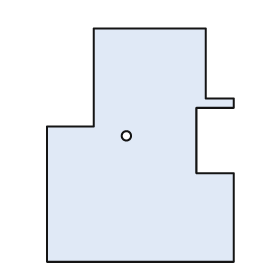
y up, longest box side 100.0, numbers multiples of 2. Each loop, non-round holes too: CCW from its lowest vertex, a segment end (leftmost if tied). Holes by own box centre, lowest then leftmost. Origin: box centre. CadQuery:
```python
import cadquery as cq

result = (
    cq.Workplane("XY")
    .moveTo(-40.0, -50.0)
    .lineTo(40.0, -50.0)
    .lineTo(40.0, -12.0)
    .lineTo(24.0, -12.0)
    .lineTo(24.0, 16.0)
    .lineTo(40.0, 16.0)
    .lineTo(40.0, 20.0)
    .lineTo(28.0, 20.0)
    .lineTo(28.0, 50.0)
    .lineTo(-20.0, 50.0)
    .lineTo(-20.0, 8.0)
    .lineTo(-40.0, 8.0)
    .close()
    .moveTo(-6.0, 4.0)
    .circle(2.0)
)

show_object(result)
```